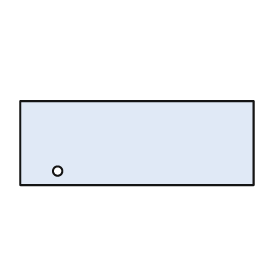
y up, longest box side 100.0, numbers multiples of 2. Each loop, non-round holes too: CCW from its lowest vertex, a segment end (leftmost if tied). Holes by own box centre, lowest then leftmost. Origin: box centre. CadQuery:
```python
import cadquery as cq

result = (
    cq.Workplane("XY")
    .moveTo(-50.0, -18.0)
    .lineTo(50.0, -18.0)
    .lineTo(50.0, 18.0)
    .lineTo(-50.0, 18.0)
    .close()
    .moveTo(-34.0, -12.0)
    .circle(2.0)
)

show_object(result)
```